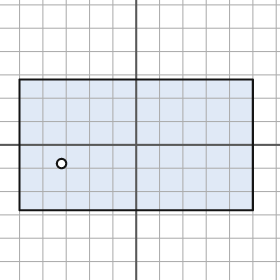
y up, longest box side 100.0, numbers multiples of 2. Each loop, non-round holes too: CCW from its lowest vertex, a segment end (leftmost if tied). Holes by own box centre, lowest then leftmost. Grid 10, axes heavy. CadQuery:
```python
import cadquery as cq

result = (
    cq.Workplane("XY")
    .moveTo(-50.0, -28.0)
    .lineTo(50.0, -28.0)
    .lineTo(50.0, 28.0)
    .lineTo(-50.0, 28.0)
    .close()
    .moveTo(-32.0, -8.0)
    .circle(2.0)
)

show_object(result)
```